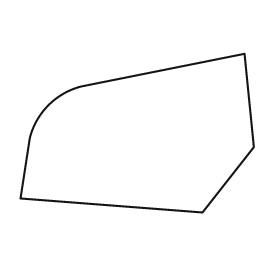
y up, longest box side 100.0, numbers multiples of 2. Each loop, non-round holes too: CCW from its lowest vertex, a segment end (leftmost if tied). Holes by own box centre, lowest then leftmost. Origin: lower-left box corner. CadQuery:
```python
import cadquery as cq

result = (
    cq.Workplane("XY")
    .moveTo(78.0, 0.0)
    .lineTo(100.0, 28.0)
    .lineTo(96.0, 68.0)
    .lineTo(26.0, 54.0)
    .threePointArc((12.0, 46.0), (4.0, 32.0))
    .lineTo(0.0, 6.0)
    .close()
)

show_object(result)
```